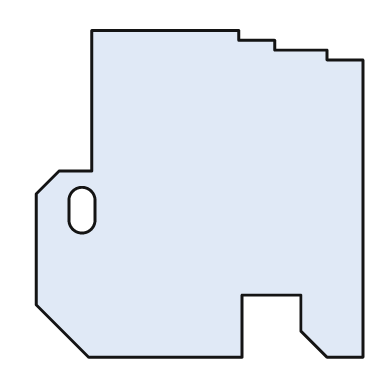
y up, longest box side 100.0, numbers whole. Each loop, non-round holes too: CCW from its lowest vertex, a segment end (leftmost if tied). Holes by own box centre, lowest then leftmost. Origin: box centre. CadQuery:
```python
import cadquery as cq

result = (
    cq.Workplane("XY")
    .moveTo(-34.0, -50.0)
    .lineTo(13.0, -50.0)
    .lineTo(13.0, -31.0)
    .lineTo(31.0, -31.0)
    .lineTo(31.0, -42.0)
    .lineTo(39.0, -50.0)
    .lineTo(50.0, -50.0)
    .lineTo(50.0, 41.0)
    .lineTo(39.0, 41.0)
    .lineTo(39.0, 44.0)
    .lineTo(23.0, 44.0)
    .lineTo(23.0, 47.0)
    .lineTo(12.0, 47.0)
    .lineTo(12.0, 50.0)
    .lineTo(-33.0, 50.0)
    .lineTo(-33.0, 7.0)
    .lineTo(-43.0, 7.0)
    .lineTo(-50.0, 0.0)
    .lineTo(-50.0, -34.0)
    .close()
    .moveTo(-40.0, -8.0)
    .threePointArc((-36.0, -12.0), (-32.0, -8.0))
    .lineTo(-32.0, -2.0)
    .threePointArc((-36.0, 2.0), (-40.0, -2.0))
    .close()
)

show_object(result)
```